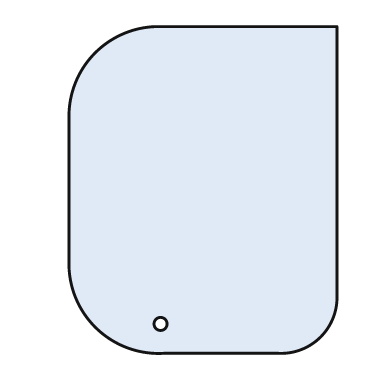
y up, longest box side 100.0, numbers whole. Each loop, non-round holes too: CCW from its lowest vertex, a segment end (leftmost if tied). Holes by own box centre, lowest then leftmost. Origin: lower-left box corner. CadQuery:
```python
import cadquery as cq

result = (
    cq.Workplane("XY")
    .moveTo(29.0, 0.0)
    .lineTo(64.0, 0.0)
    .threePointArc((77.0, 5.0), (82.0, 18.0))
    .lineTo(82.0, 100.0)
    .lineTo(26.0, 100.0)
    .threePointArc((8.0, 92.0), (0.0, 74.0))
    .lineTo(0.0, 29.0)
    .threePointArc((8.0, 8.0), (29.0, 0.0))
    .close()
    .moveTo(28.0, 9.0)
    .circle(2.0)
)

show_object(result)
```